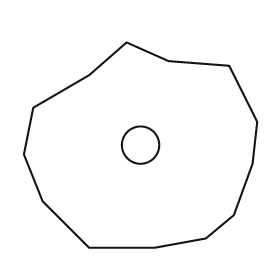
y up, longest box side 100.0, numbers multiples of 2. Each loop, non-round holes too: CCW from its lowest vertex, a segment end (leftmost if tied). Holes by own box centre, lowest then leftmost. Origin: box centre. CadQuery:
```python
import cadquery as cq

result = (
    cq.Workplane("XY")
    .moveTo(-22.0, -44.0)
    .lineTo(6.0, -44.0)
    .lineTo(28.0, -40.0)
    .lineTo(40.0, -30.0)
    .lineTo(48.0, -8.0)
    .lineTo(50.0, 10.0)
    .lineTo(38.0, 34.0)
    .lineTo(12.0, 36.0)
    .lineTo(-6.0, 44.0)
    .lineTo(-22.0, 30.0)
    .lineTo(-46.0, 16.0)
    .lineTo(-50.0, -4.0)
    .lineTo(-42.0, -24.0)
    .close()
    .moveTo(0.0, 0.0)
    .circle(8.0)
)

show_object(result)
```